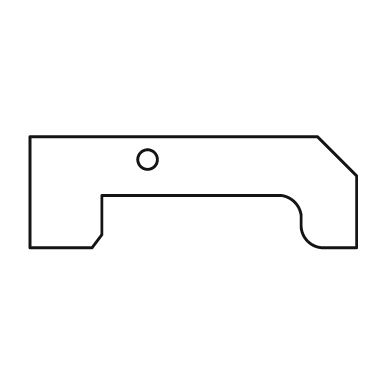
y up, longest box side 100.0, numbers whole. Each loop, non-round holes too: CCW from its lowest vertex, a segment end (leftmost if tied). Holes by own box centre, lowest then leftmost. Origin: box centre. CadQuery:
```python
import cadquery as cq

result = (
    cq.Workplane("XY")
    .moveTo(-50.0, -17.0)
    .lineTo(-31.0, -17.0)
    .lineTo(-28.0, -13.0)
    .lineTo(-28.0, -1.0)
    .lineTo(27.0, -1.0)
    .threePointArc((31.0, -3.0), (33.0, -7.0))
    .lineTo(33.0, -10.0)
    .threePointArc((35.0, -15.0), (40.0, -17.0))
    .lineTo(50.0, -17.0)
    .lineTo(50.0, 5.0)
    .lineTo(38.0, 17.0)
    .lineTo(-50.0, 17.0)
    .close()
    .moveTo(-14.0, 10.0)
    .circle(3.0)
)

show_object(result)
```